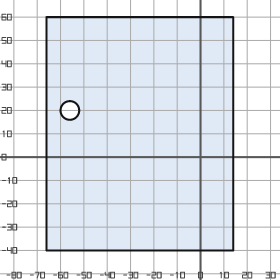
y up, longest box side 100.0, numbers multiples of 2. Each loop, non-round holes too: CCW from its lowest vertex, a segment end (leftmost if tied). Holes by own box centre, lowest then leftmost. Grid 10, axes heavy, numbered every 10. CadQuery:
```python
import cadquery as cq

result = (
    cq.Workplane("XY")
    .moveTo(-66.0, -40.0)
    .lineTo(14.0, -40.0)
    .lineTo(14.0, 60.0)
    .lineTo(-66.0, 60.0)
    .close()
    .moveTo(-56.0, 20.0)
    .circle(4.0)
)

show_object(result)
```